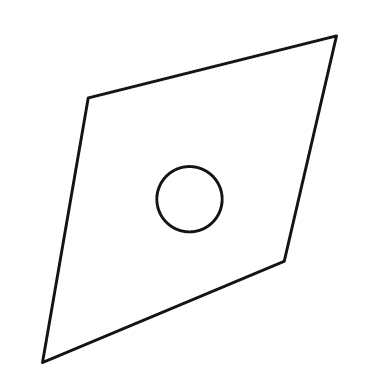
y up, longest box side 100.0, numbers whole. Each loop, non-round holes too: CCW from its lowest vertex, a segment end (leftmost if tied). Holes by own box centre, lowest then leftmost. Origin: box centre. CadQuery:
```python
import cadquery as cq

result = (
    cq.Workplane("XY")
    .moveTo(-45.0, -50.0)
    .lineTo(29.0, -19.0)
    .lineTo(45.0, 50.0)
    .lineTo(-31.0, 31.0)
    .close()
    .moveTo(0.0, 0.0)
    .circle(10.0)
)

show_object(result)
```